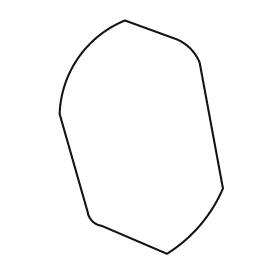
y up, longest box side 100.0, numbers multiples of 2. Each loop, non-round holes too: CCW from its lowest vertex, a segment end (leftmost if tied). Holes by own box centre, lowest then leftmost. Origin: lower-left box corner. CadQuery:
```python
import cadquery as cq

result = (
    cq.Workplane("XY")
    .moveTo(46.0, 0.0)
    .threePointArc((60.0, 12.0), (70.0, 28.0))
    .lineTo(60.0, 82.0)
    .threePointArc((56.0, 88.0), (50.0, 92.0))
    .lineTo(28.0, 100.0)
    .threePointArc((8.0, 84.0), (0.0, 60.0))
    .lineTo(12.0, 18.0)
    .threePointArc((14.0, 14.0), (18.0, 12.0))
    .close()
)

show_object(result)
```